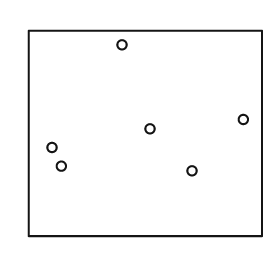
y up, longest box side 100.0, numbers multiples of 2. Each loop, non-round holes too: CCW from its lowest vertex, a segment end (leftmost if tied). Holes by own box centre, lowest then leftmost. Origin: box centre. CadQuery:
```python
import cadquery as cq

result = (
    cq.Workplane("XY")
    .moveTo(-50.0, -44.0)
    .lineTo(50.0, -44.0)
    .lineTo(50.0, 44.0)
    .lineTo(-50.0, 44.0)
    .close()
    .moveTo(20.0, -16.0)
    .circle(2.0)
    .moveTo(-36.0, -14.0)
    .circle(2.0)
    .moveTo(-40.0, -6.0)
    .circle(2.0)
    .moveTo(2.0, 2.0)
    .circle(2.0)
    .moveTo(42.0, 6.0)
    .circle(2.0)
    .moveTo(-10.0, 38.0)
    .circle(2.0)
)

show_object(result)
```